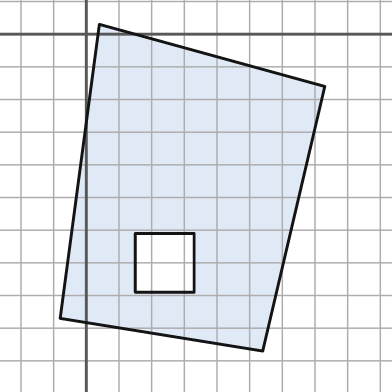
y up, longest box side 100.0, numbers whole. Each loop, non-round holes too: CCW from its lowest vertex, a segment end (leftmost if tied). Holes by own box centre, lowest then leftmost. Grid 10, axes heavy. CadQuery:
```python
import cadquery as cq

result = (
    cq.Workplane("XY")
    .moveTo(54.0, -97.0)
    .lineTo(73.0, -16.0)
    .lineTo(4.0, 3.0)
    .lineTo(-8.0, -87.0)
    .close()
    .moveTo(15.0, -79.0)
    .lineTo(33.0, -79.0)
    .lineTo(33.0, -61.0)
    .lineTo(15.0, -61.0)
    .close()
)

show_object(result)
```